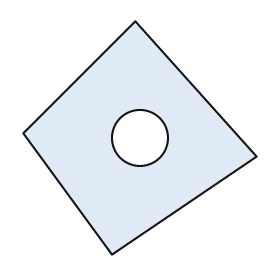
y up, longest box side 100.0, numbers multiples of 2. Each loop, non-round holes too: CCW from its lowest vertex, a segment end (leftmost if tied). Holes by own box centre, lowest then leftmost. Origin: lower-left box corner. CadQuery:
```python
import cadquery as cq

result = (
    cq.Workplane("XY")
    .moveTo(38.0, 0.0)
    .lineTo(100.0, 42.0)
    .lineTo(48.0, 100.0)
    .lineTo(0.0, 52.0)
    .close()
    .moveTo(50.0, 50.0)
    .circle(12.0)
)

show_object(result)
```